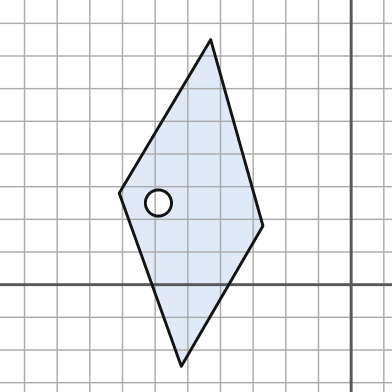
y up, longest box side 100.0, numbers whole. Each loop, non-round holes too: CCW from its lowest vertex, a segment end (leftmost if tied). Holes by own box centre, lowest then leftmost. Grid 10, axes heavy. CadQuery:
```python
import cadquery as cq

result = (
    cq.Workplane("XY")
    .moveTo(-52.0, -25.0)
    .lineTo(-27.0, 18.0)
    .lineTo(-43.0, 75.0)
    .lineTo(-71.0, 28.0)
    .close()
    .moveTo(-59.0, 25.0)
    .circle(4.0)
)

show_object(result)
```